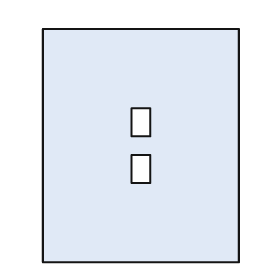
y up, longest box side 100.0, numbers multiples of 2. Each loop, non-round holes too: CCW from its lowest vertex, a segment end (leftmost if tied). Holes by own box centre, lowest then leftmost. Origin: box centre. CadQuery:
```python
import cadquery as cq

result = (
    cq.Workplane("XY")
    .moveTo(-42.0, -50.0)
    .lineTo(42.0, -50.0)
    .lineTo(42.0, 50.0)
    .lineTo(-42.0, 50.0)
    .close()
    .moveTo(-4.0, -16.0)
    .lineTo(4.0, -16.0)
    .lineTo(4.0, -4.0)
    .lineTo(-4.0, -4.0)
    .close()
    .moveTo(-4.0, 4.0)
    .lineTo(4.0, 4.0)
    .lineTo(4.0, 16.0)
    .lineTo(-4.0, 16.0)
    .close()
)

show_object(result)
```